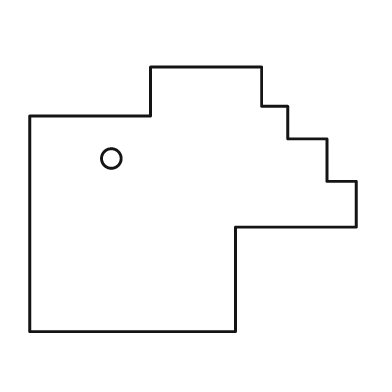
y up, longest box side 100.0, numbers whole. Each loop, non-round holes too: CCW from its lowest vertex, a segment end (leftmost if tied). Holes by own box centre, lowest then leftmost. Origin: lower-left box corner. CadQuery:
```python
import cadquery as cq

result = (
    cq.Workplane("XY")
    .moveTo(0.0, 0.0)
    .lineTo(63.0, 0.0)
    .lineTo(63.0, 32.0)
    .lineTo(100.0, 32.0)
    .lineTo(100.0, 46.0)
    .lineTo(91.0, 46.0)
    .lineTo(91.0, 59.0)
    .lineTo(79.0, 59.0)
    .lineTo(79.0, 69.0)
    .lineTo(71.0, 69.0)
    .lineTo(71.0, 81.0)
    .lineTo(37.0, 81.0)
    .lineTo(37.0, 66.0)
    .lineTo(0.0, 66.0)
    .close()
    .moveTo(25.0, 53.0)
    .circle(3.0)
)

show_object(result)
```